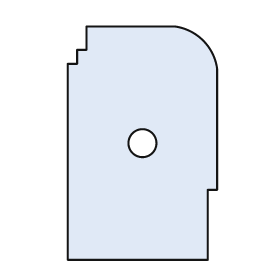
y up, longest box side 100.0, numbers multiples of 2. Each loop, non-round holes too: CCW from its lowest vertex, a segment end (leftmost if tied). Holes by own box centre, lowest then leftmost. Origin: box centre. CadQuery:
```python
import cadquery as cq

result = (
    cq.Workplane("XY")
    .moveTo(-32.0, -50.0)
    .lineTo(28.0, -50.0)
    .lineTo(28.0, -20.0)
    .lineTo(32.0, -20.0)
    .lineTo(32.0, 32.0)
    .threePointArc((26.0, 44.0), (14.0, 50.0))
    .lineTo(-24.0, 50.0)
    .lineTo(-24.0, 40.0)
    .lineTo(-28.0, 40.0)
    .lineTo(-28.0, 34.0)
    .lineTo(-32.0, 34.0)
    .close()
    .moveTo(0.0, 0.0)
    .circle(6.0)
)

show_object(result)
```